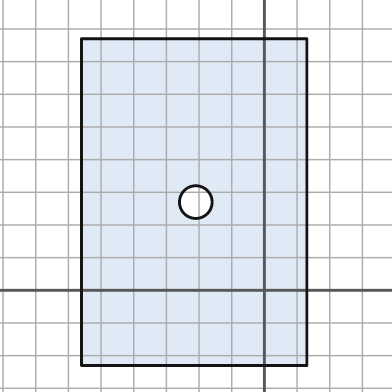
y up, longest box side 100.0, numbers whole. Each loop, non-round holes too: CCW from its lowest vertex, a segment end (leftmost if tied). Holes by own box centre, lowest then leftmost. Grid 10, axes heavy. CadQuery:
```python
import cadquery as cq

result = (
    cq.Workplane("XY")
    .moveTo(-56.0, -23.0)
    .lineTo(13.0, -23.0)
    .lineTo(13.0, 77.0)
    .lineTo(-56.0, 77.0)
    .close()
    .moveTo(-21.0, 27.0)
    .circle(5.0)
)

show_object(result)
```